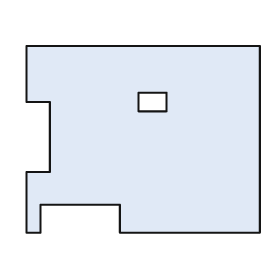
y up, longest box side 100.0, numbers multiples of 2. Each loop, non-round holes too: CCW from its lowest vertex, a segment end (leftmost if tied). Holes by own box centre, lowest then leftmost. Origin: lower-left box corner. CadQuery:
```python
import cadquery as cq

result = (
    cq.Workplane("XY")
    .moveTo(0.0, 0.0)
    .lineTo(6.0, 0.0)
    .lineTo(6.0, 12.0)
    .lineTo(40.0, 12.0)
    .lineTo(40.0, 0.0)
    .lineTo(100.0, 0.0)
    .lineTo(100.0, 80.0)
    .lineTo(0.0, 80.0)
    .lineTo(0.0, 56.0)
    .lineTo(10.0, 56.0)
    .lineTo(10.0, 26.0)
    .lineTo(0.0, 26.0)
    .close()
    .moveTo(48.0, 52.0)
    .lineTo(60.0, 52.0)
    .lineTo(60.0, 60.0)
    .lineTo(48.0, 60.0)
    .close()
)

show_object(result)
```